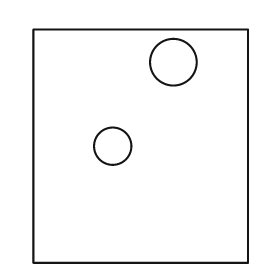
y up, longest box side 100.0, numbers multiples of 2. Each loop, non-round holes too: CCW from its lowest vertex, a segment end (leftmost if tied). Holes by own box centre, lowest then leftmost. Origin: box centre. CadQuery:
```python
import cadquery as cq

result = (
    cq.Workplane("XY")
    .moveTo(-46.0, -50.0)
    .lineTo(46.0, -50.0)
    .lineTo(46.0, 50.0)
    .lineTo(-46.0, 50.0)
    .close()
    .moveTo(-12.0, 0.0)
    .circle(8.0)
    .moveTo(14.0, 36.0)
    .circle(10.0)
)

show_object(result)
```